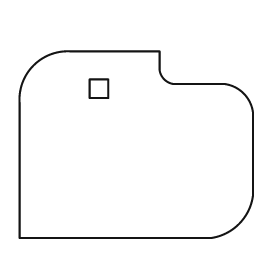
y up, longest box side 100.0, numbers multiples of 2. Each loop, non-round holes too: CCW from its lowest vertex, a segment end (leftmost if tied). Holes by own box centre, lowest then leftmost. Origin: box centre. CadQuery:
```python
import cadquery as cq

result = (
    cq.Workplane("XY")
    .moveTo(-50.0, -40.0)
    .lineTo(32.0, -40.0)
    .threePointArc((44.0, -34.0), (50.0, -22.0))
    .lineTo(50.0, 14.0)
    .threePointArc((46.0, 22.0), (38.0, 26.0))
    .lineTo(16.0, 26.0)
    .threePointArc((12.0, 28.0), (10.0, 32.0))
    .lineTo(10.0, 40.0)
    .lineTo(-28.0, 40.0)
    .threePointArc((-44.0, 34.0), (-50.0, 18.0))
    .close()
    .moveTo(-20.0, 20.0)
    .lineTo(-12.0, 20.0)
    .lineTo(-12.0, 28.0)
    .lineTo(-20.0, 28.0)
    .close()
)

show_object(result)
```